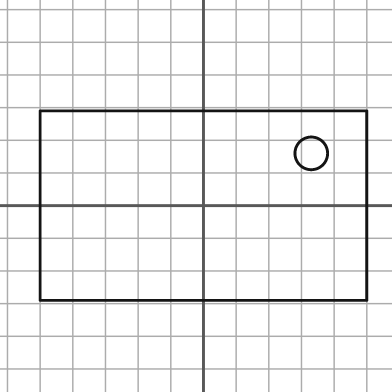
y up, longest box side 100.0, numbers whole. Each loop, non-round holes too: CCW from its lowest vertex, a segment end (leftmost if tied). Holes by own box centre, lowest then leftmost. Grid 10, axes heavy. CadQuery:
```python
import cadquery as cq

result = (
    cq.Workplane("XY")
    .moveTo(-50.0, -29.0)
    .lineTo(50.0, -29.0)
    .lineTo(50.0, 29.0)
    .lineTo(-50.0, 29.0)
    .close()
    .moveTo(33.0, 16.0)
    .circle(5.0)
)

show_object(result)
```